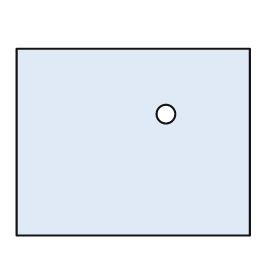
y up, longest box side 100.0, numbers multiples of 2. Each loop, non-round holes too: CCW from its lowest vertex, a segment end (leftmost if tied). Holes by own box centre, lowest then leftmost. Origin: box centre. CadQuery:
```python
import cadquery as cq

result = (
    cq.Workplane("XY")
    .moveTo(-50.0, -40.0)
    .lineTo(50.0, -40.0)
    .lineTo(50.0, 40.0)
    .lineTo(-50.0, 40.0)
    .close()
    .moveTo(14.0, 12.0)
    .circle(4.0)
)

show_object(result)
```